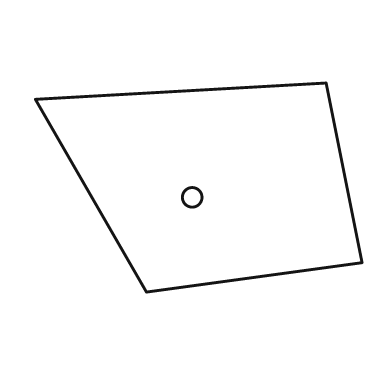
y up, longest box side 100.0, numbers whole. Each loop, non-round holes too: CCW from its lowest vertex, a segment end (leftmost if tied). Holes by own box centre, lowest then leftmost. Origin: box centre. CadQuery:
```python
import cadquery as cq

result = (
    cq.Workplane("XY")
    .moveTo(-16.0, -32.0)
    .lineTo(50.0, -23.0)
    .lineTo(39.0, 32.0)
    .lineTo(-50.0, 27.0)
    .close()
    .moveTo(-2.0, -3.0)
    .circle(3.0)
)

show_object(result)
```